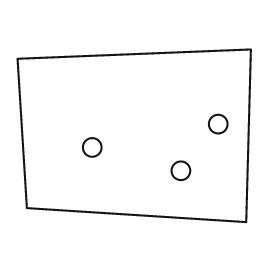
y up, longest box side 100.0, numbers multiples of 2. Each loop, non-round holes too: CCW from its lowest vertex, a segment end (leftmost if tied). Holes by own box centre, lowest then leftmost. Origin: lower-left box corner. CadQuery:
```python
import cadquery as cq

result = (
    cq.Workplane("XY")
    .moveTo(98.0, 0.0)
    .lineTo(100.0, 74.0)
    .lineTo(0.0, 70.0)
    .lineTo(4.0, 6.0)
    .close()
    .moveTo(70.0, 22.0)
    .circle(4.0)
    .moveTo(32.0, 32.0)
    .circle(4.0)
    .moveTo(86.0, 42.0)
    .circle(4.0)
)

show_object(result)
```